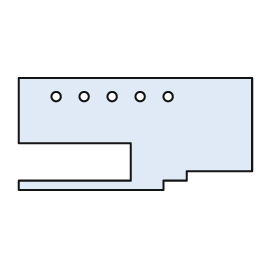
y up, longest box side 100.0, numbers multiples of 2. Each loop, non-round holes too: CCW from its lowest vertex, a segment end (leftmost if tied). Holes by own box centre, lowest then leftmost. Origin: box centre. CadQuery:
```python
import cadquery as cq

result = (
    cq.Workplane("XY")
    .moveTo(-50.0, -24.0)
    .lineTo(12.0, -24.0)
    .lineTo(12.0, -20.0)
    .lineTo(22.0, -20.0)
    .lineTo(22.0, -16.0)
    .lineTo(50.0, -16.0)
    .lineTo(50.0, 24.0)
    .lineTo(-50.0, 24.0)
    .lineTo(-50.0, -4.0)
    .lineTo(-2.0, -4.0)
    .lineTo(-2.0, -20.0)
    .lineTo(-50.0, -20.0)
    .close()
    .moveTo(-34.0, 16.0)
    .circle(2.0)
    .moveTo(-22.0, 16.0)
    .circle(2.0)
    .moveTo(-10.0, 16.0)
    .circle(2.0)
    .moveTo(2.0, 16.0)
    .circle(2.0)
    .moveTo(14.0, 16.0)
    .circle(2.0)
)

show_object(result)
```